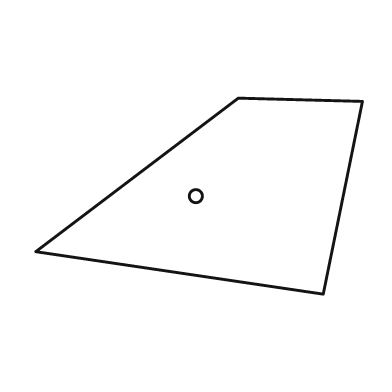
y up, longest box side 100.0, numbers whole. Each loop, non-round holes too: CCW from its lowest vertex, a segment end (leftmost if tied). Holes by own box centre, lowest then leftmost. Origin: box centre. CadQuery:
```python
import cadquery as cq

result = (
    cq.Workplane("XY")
    .moveTo(38.0, -30.0)
    .lineTo(50.0, 29.0)
    .lineTo(12.0, 30.0)
    .lineTo(-50.0, -17.0)
    .close()
    .moveTo(-1.0, 0.0)
    .circle(2.0)
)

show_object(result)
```